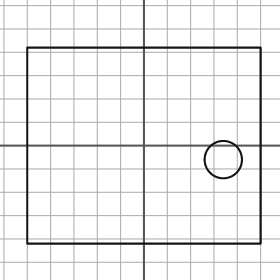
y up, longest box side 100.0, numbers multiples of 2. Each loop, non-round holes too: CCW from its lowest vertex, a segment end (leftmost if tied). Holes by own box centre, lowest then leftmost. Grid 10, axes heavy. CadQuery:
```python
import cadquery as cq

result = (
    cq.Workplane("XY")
    .moveTo(-50.0, -42.0)
    .lineTo(50.0, -42.0)
    .lineTo(50.0, 42.0)
    .lineTo(-50.0, 42.0)
    .close()
    .moveTo(34.0, -6.0)
    .circle(8.0)
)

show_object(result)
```